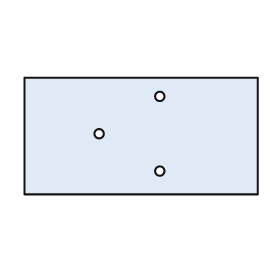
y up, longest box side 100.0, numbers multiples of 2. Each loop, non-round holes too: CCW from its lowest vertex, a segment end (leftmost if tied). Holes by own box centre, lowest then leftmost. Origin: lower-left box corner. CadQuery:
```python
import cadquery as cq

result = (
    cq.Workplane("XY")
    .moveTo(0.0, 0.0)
    .lineTo(100.0, 0.0)
    .lineTo(100.0, 50.0)
    .lineTo(0.0, 50.0)
    .close()
    .moveTo(58.0, 10.0)
    .circle(2.0)
    .moveTo(32.0, 26.0)
    .circle(2.0)
    .moveTo(58.0, 42.0)
    .circle(2.0)
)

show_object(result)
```